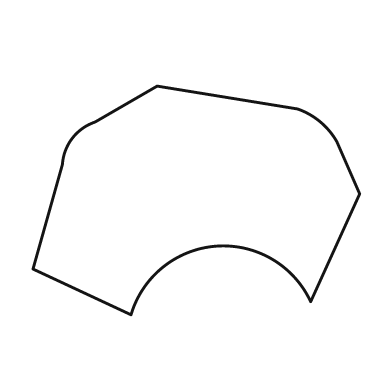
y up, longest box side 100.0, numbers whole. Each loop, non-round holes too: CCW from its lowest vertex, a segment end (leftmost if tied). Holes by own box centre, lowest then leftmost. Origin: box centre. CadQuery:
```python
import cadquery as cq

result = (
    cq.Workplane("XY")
    .moveTo(-20.0, -35.0)
    .threePointArc((6.0, -14.0), (35.0, -31.0))
    .lineTo(50.0, 2.0)
    .lineTo(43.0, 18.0)
    .threePointArc((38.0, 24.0), (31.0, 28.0))
    .lineTo(-12.0, 35.0)
    .lineTo(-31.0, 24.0)
    .threePointArc((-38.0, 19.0), (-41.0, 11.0))
    .lineTo(-50.0, -21.0)
    .close()
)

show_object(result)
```